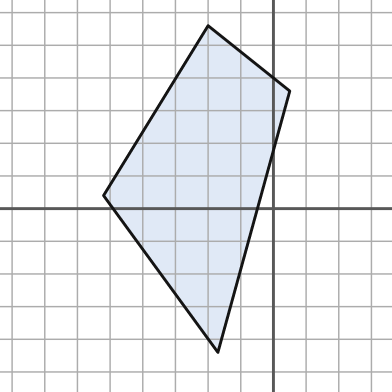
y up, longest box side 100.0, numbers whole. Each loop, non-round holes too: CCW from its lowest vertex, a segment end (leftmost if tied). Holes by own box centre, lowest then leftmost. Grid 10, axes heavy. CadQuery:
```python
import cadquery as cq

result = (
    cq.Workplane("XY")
    .moveTo(-17.0, -44.0)
    .lineTo(5.0, 36.0)
    .lineTo(-20.0, 56.0)
    .lineTo(-52.0, 4.0)
    .close()
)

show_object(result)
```